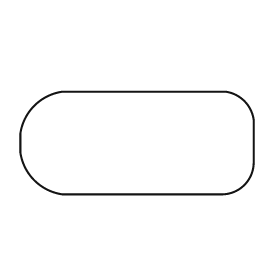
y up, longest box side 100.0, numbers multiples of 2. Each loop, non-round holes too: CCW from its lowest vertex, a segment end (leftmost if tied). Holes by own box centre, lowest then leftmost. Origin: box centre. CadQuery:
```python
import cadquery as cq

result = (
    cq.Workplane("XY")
    .moveTo(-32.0, -22.0)
    .lineTo(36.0, -22.0)
    .threePointArc((46.0, -18.0), (50.0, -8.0))
    .lineTo(50.0, 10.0)
    .threePointArc((46.0, 18.0), (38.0, 22.0))
    .lineTo(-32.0, 22.0)
    .threePointArc((-44.0, 16.0), (-50.0, 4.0))
    .lineTo(-50.0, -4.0)
    .threePointArc((-44.0, -16.0), (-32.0, -22.0))
    .close()
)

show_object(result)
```